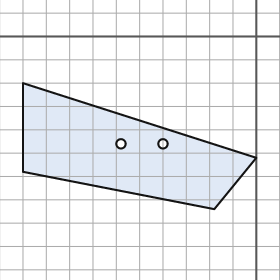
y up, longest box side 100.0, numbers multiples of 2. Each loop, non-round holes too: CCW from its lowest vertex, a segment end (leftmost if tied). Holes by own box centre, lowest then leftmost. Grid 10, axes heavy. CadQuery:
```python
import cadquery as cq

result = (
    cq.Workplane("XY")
    .moveTo(-18.0, -74.0)
    .lineTo(0.0, -52.0)
    .lineTo(-100.0, -20.0)
    .lineTo(-100.0, -58.0)
    .close()
    .moveTo(-58.0, -46.0)
    .circle(2.0)
    .moveTo(-40.0, -46.0)
    .circle(2.0)
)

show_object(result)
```